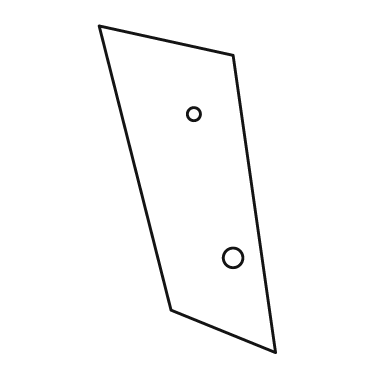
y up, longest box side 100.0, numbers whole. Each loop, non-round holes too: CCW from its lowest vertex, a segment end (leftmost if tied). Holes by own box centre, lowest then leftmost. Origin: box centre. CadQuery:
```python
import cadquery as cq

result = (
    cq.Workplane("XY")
    .moveTo(27.0, -50.0)
    .lineTo(14.0, 41.0)
    .lineTo(-27.0, 50.0)
    .lineTo(-5.0, -37.0)
    .close()
    .moveTo(14.0, -21.0)
    .circle(3.0)
    .moveTo(2.0, 23.0)
    .circle(2.0)
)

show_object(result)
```